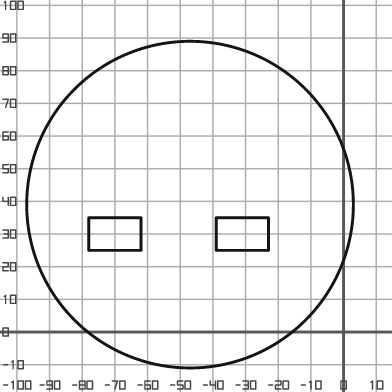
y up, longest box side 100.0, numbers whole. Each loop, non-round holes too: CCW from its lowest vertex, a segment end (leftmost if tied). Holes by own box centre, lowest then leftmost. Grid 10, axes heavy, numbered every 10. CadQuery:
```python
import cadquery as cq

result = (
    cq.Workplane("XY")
    .moveTo(-47.0, 39.0)
    .circle(50.0)
    .moveTo(-78.0, 25.0)
    .lineTo(-62.0, 25.0)
    .lineTo(-62.0, 35.0)
    .lineTo(-78.0, 35.0)
    .close()
    .moveTo(-39.0, 25.0)
    .lineTo(-23.0, 25.0)
    .lineTo(-23.0, 35.0)
    .lineTo(-39.0, 35.0)
    .close()
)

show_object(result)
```